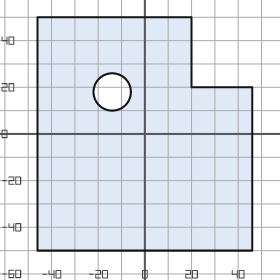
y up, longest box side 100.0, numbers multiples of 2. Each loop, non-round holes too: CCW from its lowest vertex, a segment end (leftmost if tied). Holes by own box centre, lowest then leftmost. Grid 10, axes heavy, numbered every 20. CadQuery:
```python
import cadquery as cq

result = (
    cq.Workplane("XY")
    .moveTo(-46.0, -50.0)
    .lineTo(46.0, -50.0)
    .lineTo(46.0, 20.0)
    .lineTo(20.0, 20.0)
    .lineTo(20.0, 50.0)
    .lineTo(-46.0, 50.0)
    .close()
    .moveTo(-14.0, 18.0)
    .circle(8.0)
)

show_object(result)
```